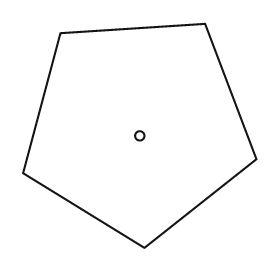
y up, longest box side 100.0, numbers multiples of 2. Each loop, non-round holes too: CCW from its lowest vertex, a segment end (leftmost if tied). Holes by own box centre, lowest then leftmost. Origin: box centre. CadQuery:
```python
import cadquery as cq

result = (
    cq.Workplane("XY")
    .moveTo(2.0, -48.0)
    .lineTo(50.0, -10.0)
    .lineTo(28.0, 48.0)
    .lineTo(-34.0, 44.0)
    .lineTo(-50.0, -16.0)
    .close()
    .moveTo(0.0, 0.0)
    .circle(2.0)
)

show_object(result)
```